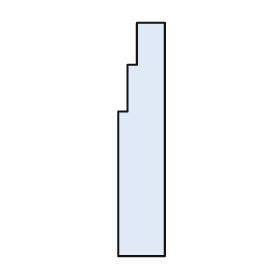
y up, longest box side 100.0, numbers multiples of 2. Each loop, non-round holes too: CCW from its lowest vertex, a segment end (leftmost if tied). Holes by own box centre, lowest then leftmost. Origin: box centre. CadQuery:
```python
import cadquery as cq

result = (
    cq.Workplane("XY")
    .moveTo(-10.0, -50.0)
    .lineTo(10.0, -50.0)
    .lineTo(10.0, 50.0)
    .lineTo(-2.0, 50.0)
    .lineTo(-2.0, 32.0)
    .lineTo(-6.0, 32.0)
    .lineTo(-6.0, 12.0)
    .lineTo(-10.0, 12.0)
    .close()
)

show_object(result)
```